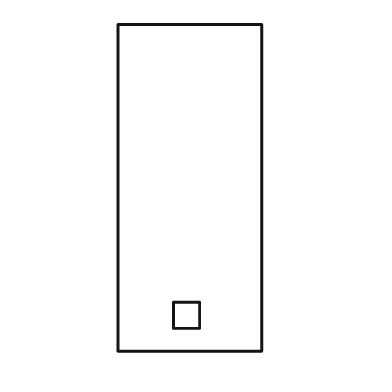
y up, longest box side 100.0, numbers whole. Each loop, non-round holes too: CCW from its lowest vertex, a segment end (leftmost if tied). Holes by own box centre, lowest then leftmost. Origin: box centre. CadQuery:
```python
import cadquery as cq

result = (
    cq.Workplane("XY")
    .moveTo(-22.0, -50.0)
    .lineTo(22.0, -50.0)
    .lineTo(22.0, 50.0)
    .lineTo(-22.0, 50.0)
    .close()
    .moveTo(-5.0, -43.0)
    .lineTo(3.0, -43.0)
    .lineTo(3.0, -35.0)
    .lineTo(-5.0, -35.0)
    .close()
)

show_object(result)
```